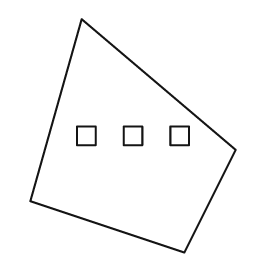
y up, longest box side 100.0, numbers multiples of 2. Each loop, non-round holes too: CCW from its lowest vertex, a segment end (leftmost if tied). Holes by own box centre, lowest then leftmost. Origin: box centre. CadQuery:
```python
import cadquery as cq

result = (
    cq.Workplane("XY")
    .moveTo(22.0, -50.0)
    .lineTo(44.0, -6.0)
    .lineTo(-22.0, 50.0)
    .lineTo(-44.0, -28.0)
    .close()
    .moveTo(-24.0, -4.0)
    .lineTo(-16.0, -4.0)
    .lineTo(-16.0, 4.0)
    .lineTo(-24.0, 4.0)
    .close()
    .moveTo(-4.0, -4.0)
    .lineTo(4.0, -4.0)
    .lineTo(4.0, 4.0)
    .lineTo(-4.0, 4.0)
    .close()
    .moveTo(16.0, -4.0)
    .lineTo(24.0, -4.0)
    .lineTo(24.0, 4.0)
    .lineTo(16.0, 4.0)
    .close()
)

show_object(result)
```